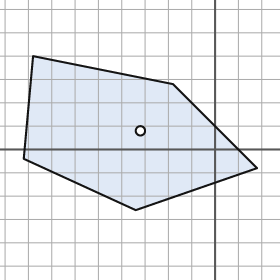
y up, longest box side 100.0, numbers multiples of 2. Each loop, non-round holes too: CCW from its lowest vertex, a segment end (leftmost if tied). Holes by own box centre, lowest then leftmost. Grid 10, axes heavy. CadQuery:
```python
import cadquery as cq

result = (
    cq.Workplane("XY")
    .moveTo(-34.0, -26.0)
    .lineTo(18.0, -8.0)
    .lineTo(-18.0, 28.0)
    .lineTo(-78.0, 40.0)
    .lineTo(-82.0, -4.0)
    .close()
    .moveTo(-32.0, 8.0)
    .circle(2.0)
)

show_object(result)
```